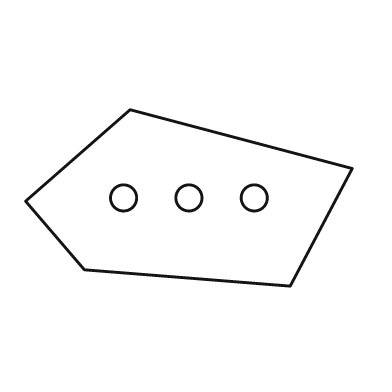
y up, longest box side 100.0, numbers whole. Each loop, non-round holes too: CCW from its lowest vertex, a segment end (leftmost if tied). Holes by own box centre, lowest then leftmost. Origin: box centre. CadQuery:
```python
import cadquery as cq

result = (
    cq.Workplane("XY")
    .moveTo(31.0, -27.0)
    .lineTo(50.0, 9.0)
    .lineTo(-18.0, 27.0)
    .lineTo(-50.0, -1.0)
    .lineTo(-32.0, -22.0)
    .close()
    .moveTo(-20.0, 0.0)
    .circle(4.0)
    .moveTo(0.0, 0.0)
    .circle(4.0)
    .moveTo(20.0, 0.0)
    .circle(4.0)
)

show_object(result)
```